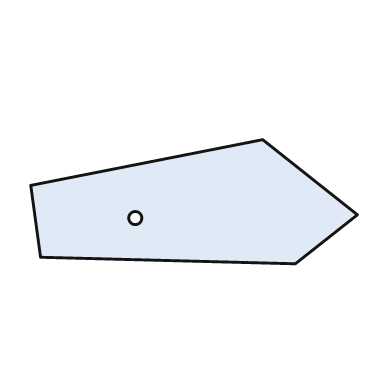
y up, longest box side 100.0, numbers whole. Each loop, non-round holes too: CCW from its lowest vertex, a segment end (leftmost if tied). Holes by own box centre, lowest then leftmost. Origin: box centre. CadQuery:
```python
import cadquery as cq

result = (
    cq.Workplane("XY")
    .moveTo(31.0, -19.0)
    .lineTo(50.0, -4.0)
    .lineTo(21.0, 19.0)
    .lineTo(-50.0, 5.0)
    .lineTo(-47.0, -17.0)
    .close()
    .moveTo(-18.0, -5.0)
    .circle(2.0)
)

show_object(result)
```